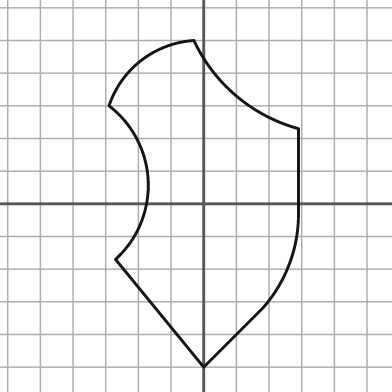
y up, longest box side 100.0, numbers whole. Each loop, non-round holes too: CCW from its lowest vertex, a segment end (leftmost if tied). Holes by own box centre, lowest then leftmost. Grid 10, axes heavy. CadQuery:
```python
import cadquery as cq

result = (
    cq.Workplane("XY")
    .moveTo(0.0, -50.0)
    .lineTo(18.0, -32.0)
    .threePointArc((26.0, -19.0), (29.0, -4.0))
    .lineTo(29.0, 23.0)
    .threePointArc((10.0, 33.0), (-3.0, 50.0))
    .threePointArc((-19.0, 44.0), (-29.0, 30.0))
    .threePointArc((-17.0, 7.0), (-27.0, -17.0))
    .close()
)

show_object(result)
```